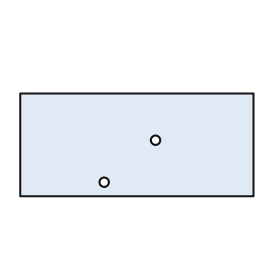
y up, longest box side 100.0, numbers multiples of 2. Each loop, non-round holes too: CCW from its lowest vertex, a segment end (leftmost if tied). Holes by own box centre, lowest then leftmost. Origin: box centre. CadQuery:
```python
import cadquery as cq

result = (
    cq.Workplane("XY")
    .moveTo(-50.0, -22.0)
    .lineTo(50.0, -22.0)
    .lineTo(50.0, 22.0)
    .lineTo(-50.0, 22.0)
    .close()
    .moveTo(-14.0, -16.0)
    .circle(2.0)
    .moveTo(8.0, 2.0)
    .circle(2.0)
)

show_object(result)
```